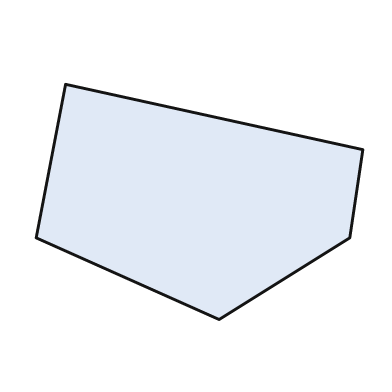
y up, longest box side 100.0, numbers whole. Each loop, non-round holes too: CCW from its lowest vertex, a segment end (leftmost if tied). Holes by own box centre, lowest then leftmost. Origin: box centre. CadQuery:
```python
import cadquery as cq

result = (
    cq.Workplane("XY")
    .moveTo(6.0, -36.0)
    .lineTo(46.0, -11.0)
    .lineTo(50.0, 16.0)
    .lineTo(-41.0, 36.0)
    .lineTo(-50.0, -11.0)
    .close()
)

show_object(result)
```